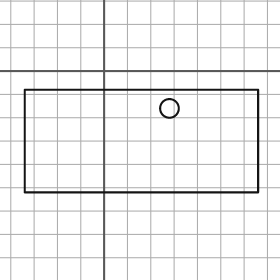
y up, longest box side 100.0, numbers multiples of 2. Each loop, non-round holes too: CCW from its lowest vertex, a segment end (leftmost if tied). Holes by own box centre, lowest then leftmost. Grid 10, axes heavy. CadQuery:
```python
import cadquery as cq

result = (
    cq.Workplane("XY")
    .moveTo(-34.0, -52.0)
    .lineTo(66.0, -52.0)
    .lineTo(66.0, -8.0)
    .lineTo(-34.0, -8.0)
    .close()
    .moveTo(28.0, -16.0)
    .circle(4.0)
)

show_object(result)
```